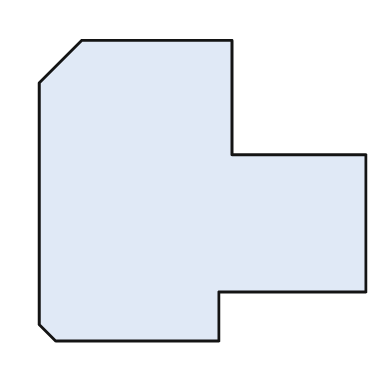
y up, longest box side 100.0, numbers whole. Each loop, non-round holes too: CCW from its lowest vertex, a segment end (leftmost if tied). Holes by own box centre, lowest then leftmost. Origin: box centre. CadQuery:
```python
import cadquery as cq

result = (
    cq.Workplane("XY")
    .moveTo(-45.0, -46.0)
    .lineTo(5.0, -46.0)
    .lineTo(5.0, -31.0)
    .lineTo(50.0, -31.0)
    .lineTo(50.0, 11.0)
    .lineTo(9.0, 11.0)
    .lineTo(9.0, 46.0)
    .lineTo(-37.0, 46.0)
    .lineTo(-50.0, 33.0)
    .lineTo(-50.0, -41.0)
    .close()
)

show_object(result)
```